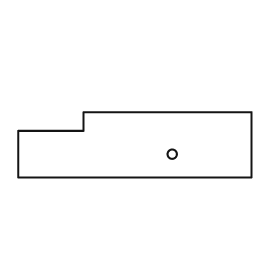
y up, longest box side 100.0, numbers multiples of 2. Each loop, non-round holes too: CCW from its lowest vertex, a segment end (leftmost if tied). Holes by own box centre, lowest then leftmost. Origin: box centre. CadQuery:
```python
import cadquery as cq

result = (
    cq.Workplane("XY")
    .moveTo(-50.0, -14.0)
    .lineTo(50.0, -14.0)
    .lineTo(50.0, 14.0)
    .lineTo(-22.0, 14.0)
    .lineTo(-22.0, 6.0)
    .lineTo(-50.0, 6.0)
    .close()
    .moveTo(16.0, -4.0)
    .circle(2.0)
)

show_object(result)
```